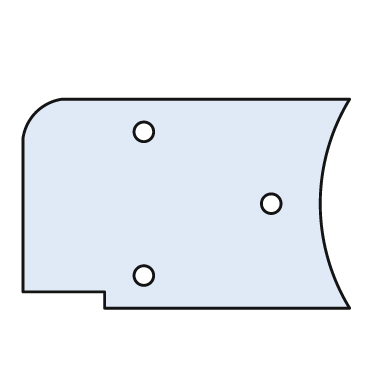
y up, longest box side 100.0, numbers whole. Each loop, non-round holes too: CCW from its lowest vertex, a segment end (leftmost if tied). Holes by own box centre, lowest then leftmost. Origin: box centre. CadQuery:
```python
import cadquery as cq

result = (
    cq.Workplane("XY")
    .moveTo(-25.0, -32.0)
    .lineTo(50.0, -32.0)
    .threePointArc((41.0, 0.0), (50.0, 32.0))
    .lineTo(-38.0, 32.0)
    .threePointArc((-46.0, 28.0), (-50.0, 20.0))
    .lineTo(-50.0, -27.0)
    .lineTo(-25.0, -27.0)
    .close()
    .moveTo(-13.0, -22.0)
    .circle(3.0)
    .moveTo(26.0, 0.0)
    .circle(3.0)
    .moveTo(-13.0, 22.0)
    .circle(3.0)
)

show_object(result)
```